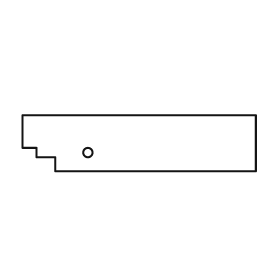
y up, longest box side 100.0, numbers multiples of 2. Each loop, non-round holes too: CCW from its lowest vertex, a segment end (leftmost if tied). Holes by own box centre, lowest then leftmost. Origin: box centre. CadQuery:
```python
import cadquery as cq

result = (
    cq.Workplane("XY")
    .moveTo(-36.0, -12.0)
    .lineTo(50.0, -12.0)
    .lineTo(50.0, 12.0)
    .lineTo(-50.0, 12.0)
    .lineTo(-50.0, -2.0)
    .lineTo(-44.0, -2.0)
    .lineTo(-44.0, -6.0)
    .lineTo(-36.0, -6.0)
    .close()
    .moveTo(-22.0, -4.0)
    .circle(2.0)
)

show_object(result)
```